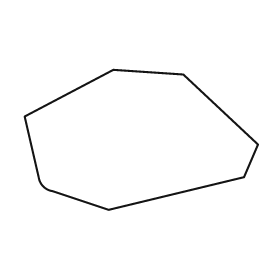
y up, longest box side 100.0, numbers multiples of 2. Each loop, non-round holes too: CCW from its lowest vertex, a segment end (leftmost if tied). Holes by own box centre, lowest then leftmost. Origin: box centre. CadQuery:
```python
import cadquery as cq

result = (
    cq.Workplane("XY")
    .moveTo(-14.0, -30.0)
    .lineTo(44.0, -16.0)
    .lineTo(50.0, -2.0)
    .lineTo(18.0, 28.0)
    .lineTo(-12.0, 30.0)
    .lineTo(-50.0, 10.0)
    .lineTo(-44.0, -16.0)
    .threePointArc((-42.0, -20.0), (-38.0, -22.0))
    .close()
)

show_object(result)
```